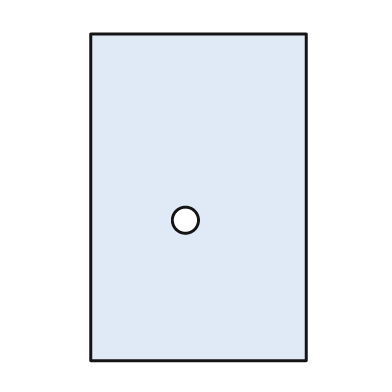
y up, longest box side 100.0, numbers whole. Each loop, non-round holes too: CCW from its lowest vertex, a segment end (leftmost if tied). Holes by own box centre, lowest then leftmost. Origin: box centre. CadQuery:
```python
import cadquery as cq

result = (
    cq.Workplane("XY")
    .moveTo(-33.0, -50.0)
    .lineTo(33.0, -50.0)
    .lineTo(33.0, 50.0)
    .lineTo(-33.0, 50.0)
    .close()
    .moveTo(-4.0, -7.0)
    .circle(4.0)
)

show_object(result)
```